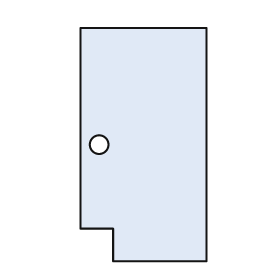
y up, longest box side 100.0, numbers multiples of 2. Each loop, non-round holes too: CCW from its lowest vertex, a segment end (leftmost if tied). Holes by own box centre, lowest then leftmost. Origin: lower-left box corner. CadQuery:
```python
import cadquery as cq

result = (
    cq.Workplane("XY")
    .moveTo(14.0, 0.0)
    .lineTo(54.0, 0.0)
    .lineTo(54.0, 100.0)
    .lineTo(0.0, 100.0)
    .lineTo(0.0, 14.0)
    .lineTo(14.0, 14.0)
    .close()
    .moveTo(8.0, 50.0)
    .circle(4.0)
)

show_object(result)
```